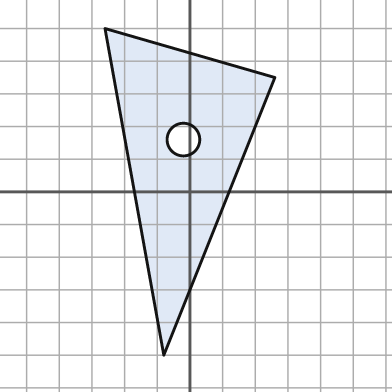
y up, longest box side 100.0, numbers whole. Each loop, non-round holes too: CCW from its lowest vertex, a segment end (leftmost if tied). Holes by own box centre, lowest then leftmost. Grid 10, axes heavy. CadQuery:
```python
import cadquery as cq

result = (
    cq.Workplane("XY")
    .moveTo(-8.0, -50.0)
    .lineTo(26.0, 35.0)
    .lineTo(-26.0, 50.0)
    .close()
    .moveTo(-2.0, 16.0)
    .circle(5.0)
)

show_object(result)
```